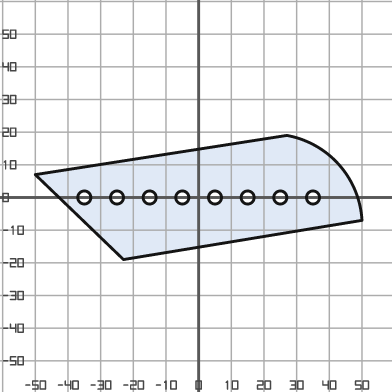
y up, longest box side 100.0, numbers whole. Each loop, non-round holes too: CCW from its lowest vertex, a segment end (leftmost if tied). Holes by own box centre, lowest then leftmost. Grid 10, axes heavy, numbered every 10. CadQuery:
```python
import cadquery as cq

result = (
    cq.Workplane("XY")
    .moveTo(-23.0, -19.0)
    .lineTo(50.0, -7.0)
    .threePointArc((43.0, 10.0), (27.0, 19.0))
    .lineTo(-50.0, 7.0)
    .close()
    .moveTo(-35.0, 0.0)
    .circle(2.0)
    .moveTo(-25.0, 0.0)
    .circle(2.0)
    .moveTo(-15.0, 0.0)
    .circle(2.0)
    .moveTo(-5.0, 0.0)
    .circle(2.0)
    .moveTo(5.0, 0.0)
    .circle(2.0)
    .moveTo(15.0, 0.0)
    .circle(2.0)
    .moveTo(25.0, 0.0)
    .circle(2.0)
    .moveTo(35.0, 0.0)
    .circle(2.0)
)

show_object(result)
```